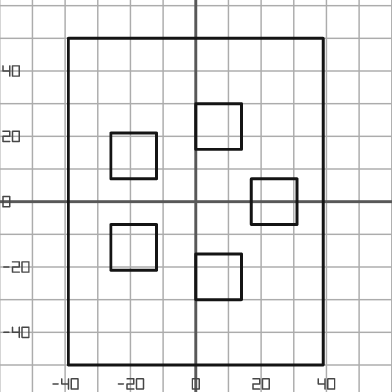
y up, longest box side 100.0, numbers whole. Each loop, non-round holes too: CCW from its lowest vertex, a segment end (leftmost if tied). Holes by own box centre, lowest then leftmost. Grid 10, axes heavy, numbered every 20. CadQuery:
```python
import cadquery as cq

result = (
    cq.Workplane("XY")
    .moveTo(-39.0, -50.0)
    .lineTo(39.0, -50.0)
    .lineTo(39.0, 50.0)
    .lineTo(-39.0, 50.0)
    .close()
    .moveTo(0.0, -30.0)
    .lineTo(14.0, -30.0)
    .lineTo(14.0, -16.0)
    .lineTo(0.0, -16.0)
    .close()
    .moveTo(-26.0, -21.0)
    .lineTo(-12.0, -21.0)
    .lineTo(-12.0, -7.0)
    .lineTo(-26.0, -7.0)
    .close()
    .moveTo(17.0, -7.0)
    .lineTo(31.0, -7.0)
    .lineTo(31.0, 7.0)
    .lineTo(17.0, 7.0)
    .close()
    .moveTo(-26.0, 7.0)
    .lineTo(-12.0, 7.0)
    .lineTo(-12.0, 21.0)
    .lineTo(-26.0, 21.0)
    .close()
    .moveTo(0.0, 16.0)
    .lineTo(14.0, 16.0)
    .lineTo(14.0, 30.0)
    .lineTo(0.0, 30.0)
    .close()
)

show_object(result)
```